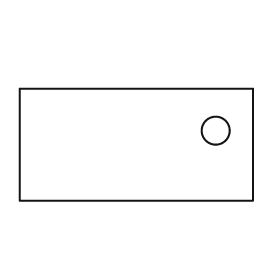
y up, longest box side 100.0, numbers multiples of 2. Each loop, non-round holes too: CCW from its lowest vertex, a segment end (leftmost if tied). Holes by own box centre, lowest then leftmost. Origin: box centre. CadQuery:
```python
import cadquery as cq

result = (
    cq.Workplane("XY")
    .moveTo(-50.0, -24.0)
    .lineTo(50.0, -24.0)
    .lineTo(50.0, 24.0)
    .lineTo(-50.0, 24.0)
    .close()
    .moveTo(34.0, 6.0)
    .circle(6.0)
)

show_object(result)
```